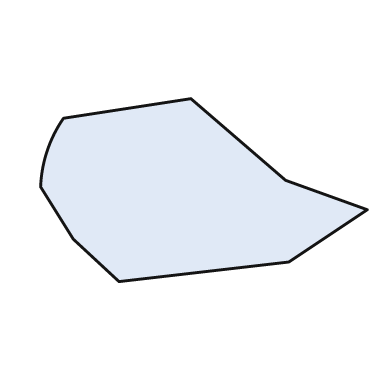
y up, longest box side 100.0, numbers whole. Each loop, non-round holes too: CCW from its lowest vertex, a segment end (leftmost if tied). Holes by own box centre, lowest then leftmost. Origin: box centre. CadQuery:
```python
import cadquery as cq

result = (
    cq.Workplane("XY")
    .moveTo(-26.0, -28.0)
    .lineTo(26.0, -22.0)
    .lineTo(50.0, -6.0)
    .lineTo(25.0, 3.0)
    .lineTo(-4.0, 28.0)
    .lineTo(-43.0, 22.0)
    .threePointArc((-48.0, 12.0), (-50.0, 1.0))
    .lineTo(-40.0, -15.0)
    .close()
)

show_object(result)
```